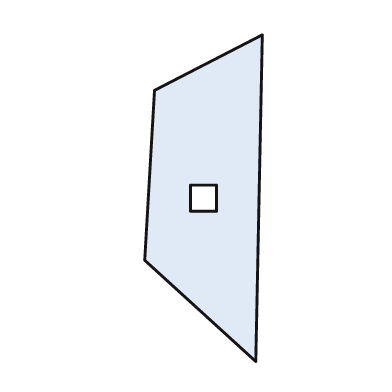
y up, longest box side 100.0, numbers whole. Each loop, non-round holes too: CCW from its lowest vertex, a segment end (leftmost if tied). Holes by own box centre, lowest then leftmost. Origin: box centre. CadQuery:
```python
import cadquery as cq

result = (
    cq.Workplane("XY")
    .moveTo(16.0, -50.0)
    .lineTo(18.0, 50.0)
    .lineTo(-15.0, 33.0)
    .lineTo(-18.0, -19.0)
    .close()
    .moveTo(-4.0, -4.0)
    .lineTo(4.0, -4.0)
    .lineTo(4.0, 4.0)
    .lineTo(-4.0, 4.0)
    .close()
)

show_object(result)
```